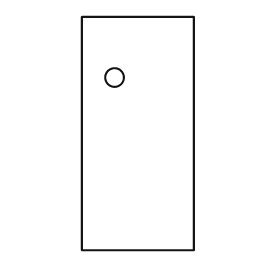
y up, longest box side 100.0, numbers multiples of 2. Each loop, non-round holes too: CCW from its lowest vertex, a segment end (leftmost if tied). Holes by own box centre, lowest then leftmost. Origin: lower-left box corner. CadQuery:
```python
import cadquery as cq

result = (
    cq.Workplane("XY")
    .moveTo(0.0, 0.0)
    .lineTo(48.0, 0.0)
    .lineTo(48.0, 100.0)
    .lineTo(0.0, 100.0)
    .close()
    .moveTo(14.0, 74.0)
    .circle(4.0)
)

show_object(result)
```